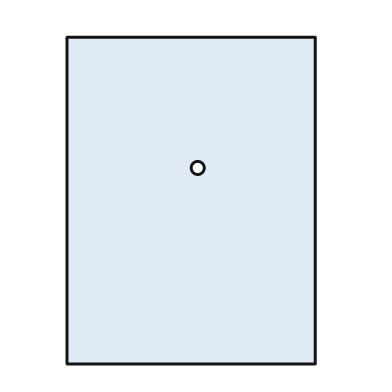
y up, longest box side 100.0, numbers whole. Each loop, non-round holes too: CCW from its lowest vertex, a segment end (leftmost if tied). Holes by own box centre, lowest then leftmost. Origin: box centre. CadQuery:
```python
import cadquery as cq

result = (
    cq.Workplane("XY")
    .moveTo(-38.0, -50.0)
    .lineTo(38.0, -50.0)
    .lineTo(38.0, 50.0)
    .lineTo(-38.0, 50.0)
    .close()
    .moveTo(2.0, 10.0)
    .circle(2.0)
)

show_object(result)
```